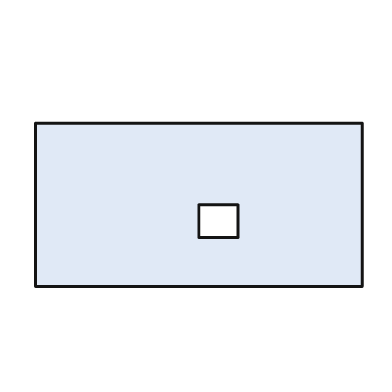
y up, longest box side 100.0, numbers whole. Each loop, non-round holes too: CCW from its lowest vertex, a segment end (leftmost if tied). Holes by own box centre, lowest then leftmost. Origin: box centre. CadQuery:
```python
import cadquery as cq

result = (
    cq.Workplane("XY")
    .moveTo(-50.0, -25.0)
    .lineTo(50.0, -25.0)
    .lineTo(50.0, 25.0)
    .lineTo(-50.0, 25.0)
    .close()
    .moveTo(0.0, -10.0)
    .lineTo(12.0, -10.0)
    .lineTo(12.0, 0.0)
    .lineTo(0.0, 0.0)
    .close()
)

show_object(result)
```